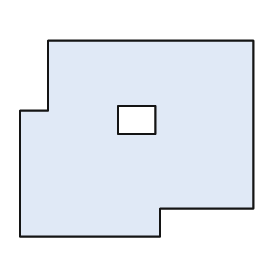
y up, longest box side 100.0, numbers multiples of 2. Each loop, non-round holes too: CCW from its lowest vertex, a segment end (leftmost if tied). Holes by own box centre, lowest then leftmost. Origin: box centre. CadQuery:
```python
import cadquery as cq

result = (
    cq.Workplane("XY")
    .moveTo(-50.0, -42.0)
    .lineTo(10.0, -42.0)
    .lineTo(10.0, -30.0)
    .lineTo(50.0, -30.0)
    .lineTo(50.0, 42.0)
    .lineTo(-38.0, 42.0)
    .lineTo(-38.0, 12.0)
    .lineTo(-50.0, 12.0)
    .close()
    .moveTo(-8.0, 2.0)
    .lineTo(8.0, 2.0)
    .lineTo(8.0, 14.0)
    .lineTo(-8.0, 14.0)
    .close()
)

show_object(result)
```